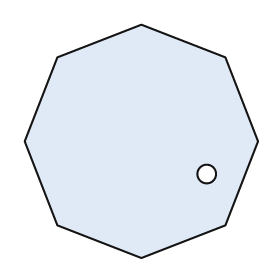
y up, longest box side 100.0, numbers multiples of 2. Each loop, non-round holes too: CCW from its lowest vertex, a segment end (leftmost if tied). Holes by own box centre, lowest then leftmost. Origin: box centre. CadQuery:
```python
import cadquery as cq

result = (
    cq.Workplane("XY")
    .moveTo(0.0, -50.0)
    .lineTo(36.0, -36.0)
    .lineTo(50.0, 0.0)
    .lineTo(36.0, 36.0)
    .lineTo(0.0, 50.0)
    .lineTo(-36.0, 36.0)
    .lineTo(-50.0, 0.0)
    .lineTo(-36.0, -36.0)
    .close()
    .moveTo(28.0, -14.0)
    .circle(4.0)
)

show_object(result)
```